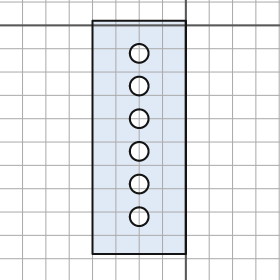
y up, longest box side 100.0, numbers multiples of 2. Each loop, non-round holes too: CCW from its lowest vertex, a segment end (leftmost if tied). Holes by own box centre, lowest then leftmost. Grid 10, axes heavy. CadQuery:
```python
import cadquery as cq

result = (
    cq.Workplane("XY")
    .moveTo(-40.0, -98.0)
    .lineTo(0.0, -98.0)
    .lineTo(0.0, 2.0)
    .lineTo(-40.0, 2.0)
    .close()
    .moveTo(-20.0, -82.0)
    .circle(4.0)
    .moveTo(-20.0, -68.0)
    .circle(4.0)
    .moveTo(-20.0, -54.0)
    .circle(4.0)
    .moveTo(-20.0, -40.0)
    .circle(4.0)
    .moveTo(-20.0, -26.0)
    .circle(4.0)
    .moveTo(-20.0, -12.0)
    .circle(4.0)
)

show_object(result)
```